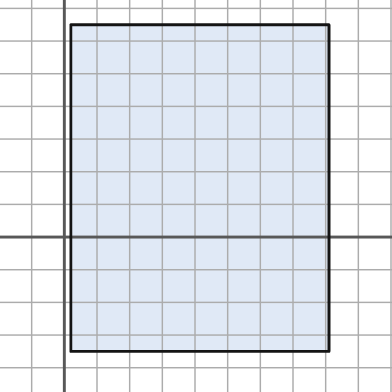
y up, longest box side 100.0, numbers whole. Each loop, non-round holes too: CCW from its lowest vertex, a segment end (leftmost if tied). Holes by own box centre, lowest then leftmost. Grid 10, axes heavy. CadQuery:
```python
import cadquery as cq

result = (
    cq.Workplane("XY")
    .moveTo(2.0, -35.0)
    .lineTo(81.0, -35.0)
    .lineTo(81.0, 65.0)
    .lineTo(2.0, 65.0)
    .close()
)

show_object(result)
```